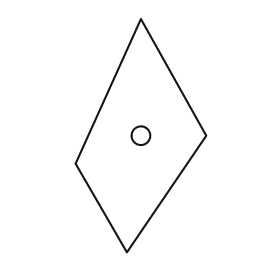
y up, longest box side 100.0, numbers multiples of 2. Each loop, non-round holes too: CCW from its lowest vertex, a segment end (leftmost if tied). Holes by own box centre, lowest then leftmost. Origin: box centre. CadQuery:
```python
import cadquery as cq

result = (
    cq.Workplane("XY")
    .moveTo(-6.0, -50.0)
    .lineTo(28.0, 0.0)
    .lineTo(0.0, 50.0)
    .lineTo(-28.0, -12.0)
    .close()
    .moveTo(0.0, 0.0)
    .circle(4.0)
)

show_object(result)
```